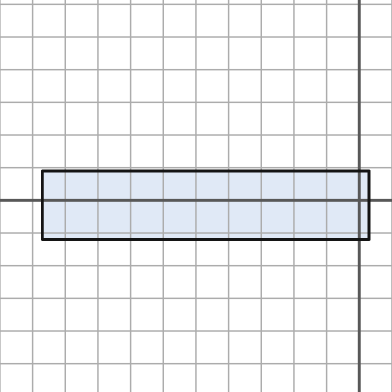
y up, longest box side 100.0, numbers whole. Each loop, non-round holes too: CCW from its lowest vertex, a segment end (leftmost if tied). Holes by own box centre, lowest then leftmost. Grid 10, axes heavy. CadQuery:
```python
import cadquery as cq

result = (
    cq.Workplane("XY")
    .moveTo(-97.0, -12.0)
    .lineTo(3.0, -12.0)
    .lineTo(3.0, 9.0)
    .lineTo(-97.0, 9.0)
    .close()
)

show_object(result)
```